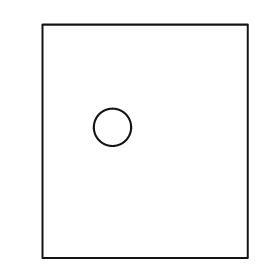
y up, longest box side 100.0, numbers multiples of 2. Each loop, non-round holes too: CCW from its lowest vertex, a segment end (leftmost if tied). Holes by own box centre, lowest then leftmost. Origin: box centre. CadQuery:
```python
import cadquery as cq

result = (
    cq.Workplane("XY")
    .moveTo(-44.0, -50.0)
    .lineTo(44.0, -50.0)
    .lineTo(44.0, 50.0)
    .lineTo(-44.0, 50.0)
    .close()
    .moveTo(-14.0, 6.0)
    .circle(8.0)
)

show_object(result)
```